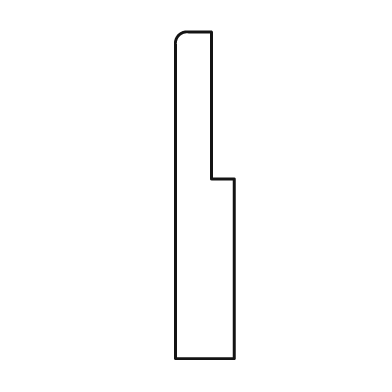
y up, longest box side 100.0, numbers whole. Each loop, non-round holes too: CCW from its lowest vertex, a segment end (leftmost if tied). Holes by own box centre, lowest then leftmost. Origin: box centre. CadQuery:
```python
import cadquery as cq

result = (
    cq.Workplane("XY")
    .moveTo(-9.0, -50.0)
    .lineTo(9.0, -50.0)
    .lineTo(9.0, 5.0)
    .lineTo(2.0, 5.0)
    .lineTo(2.0, 50.0)
    .lineTo(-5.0, 50.0)
    .threePointArc((-8.0, 49.0), (-9.0, 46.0))
    .close()
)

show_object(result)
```